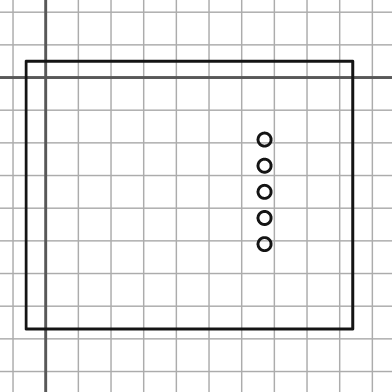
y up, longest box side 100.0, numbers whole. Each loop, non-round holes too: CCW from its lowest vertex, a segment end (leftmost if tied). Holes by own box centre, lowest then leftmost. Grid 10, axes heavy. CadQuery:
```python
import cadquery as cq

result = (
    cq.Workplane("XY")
    .moveTo(-6.0, -77.0)
    .lineTo(94.0, -77.0)
    .lineTo(94.0, 5.0)
    .lineTo(-6.0, 5.0)
    .close()
    .moveTo(67.0, -51.0)
    .circle(2.0)
    .moveTo(67.0, -43.0)
    .circle(2.0)
    .moveTo(67.0, -35.0)
    .circle(2.0)
    .moveTo(67.0, -27.0)
    .circle(2.0)
    .moveTo(67.0, -19.0)
    .circle(2.0)
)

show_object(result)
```